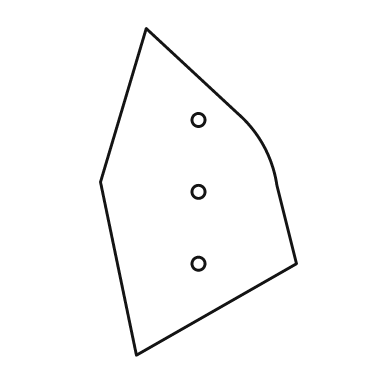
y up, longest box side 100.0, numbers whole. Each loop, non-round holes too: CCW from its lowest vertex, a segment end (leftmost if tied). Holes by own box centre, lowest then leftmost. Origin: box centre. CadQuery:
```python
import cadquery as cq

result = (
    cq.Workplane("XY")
    .moveTo(-19.0, -50.0)
    .lineTo(30.0, -22.0)
    .lineTo(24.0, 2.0)
    .threePointArc((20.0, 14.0), (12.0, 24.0))
    .lineTo(-16.0, 50.0)
    .lineTo(-30.0, 3.0)
    .close()
    .moveTo(0.0, -22.0)
    .circle(2.0)
    .moveTo(0.0, 0.0)
    .circle(2.0)
    .moveTo(0.0, 22.0)
    .circle(2.0)
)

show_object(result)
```